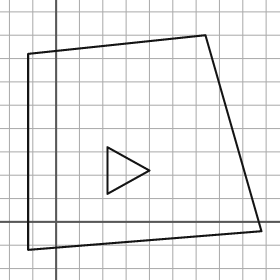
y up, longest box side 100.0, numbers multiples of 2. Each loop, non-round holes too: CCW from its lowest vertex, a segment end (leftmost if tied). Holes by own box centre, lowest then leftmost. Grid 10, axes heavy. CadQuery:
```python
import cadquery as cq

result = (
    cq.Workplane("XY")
    .moveTo(-12.0, -12.0)
    .lineTo(88.0, -4.0)
    .lineTo(64.0, 80.0)
    .lineTo(-12.0, 72.0)
    .close()
    .moveTo(22.0, 12.0)
    .lineTo(40.0, 22.0)
    .lineTo(22.0, 32.0)
    .close()
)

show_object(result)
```